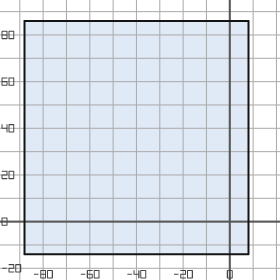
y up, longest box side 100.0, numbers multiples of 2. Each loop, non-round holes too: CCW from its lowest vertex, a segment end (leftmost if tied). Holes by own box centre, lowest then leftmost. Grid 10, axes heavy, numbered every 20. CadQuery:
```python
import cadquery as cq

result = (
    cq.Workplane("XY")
    .moveTo(-88.0, -14.0)
    .lineTo(8.0, -14.0)
    .lineTo(8.0, 86.0)
    .lineTo(-88.0, 86.0)
    .close()
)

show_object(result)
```